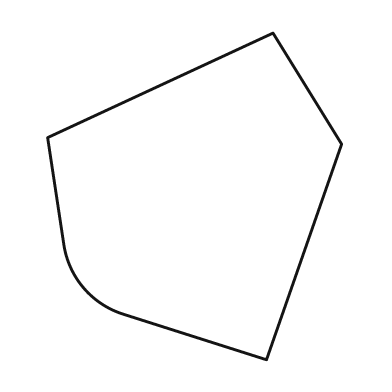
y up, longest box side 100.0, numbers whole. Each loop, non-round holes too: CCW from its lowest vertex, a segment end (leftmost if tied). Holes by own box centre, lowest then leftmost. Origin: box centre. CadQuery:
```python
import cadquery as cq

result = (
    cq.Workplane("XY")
    .moveTo(22.0, -50.0)
    .lineTo(45.0, 16.0)
    .lineTo(24.0, 50.0)
    .lineTo(-45.0, 18.0)
    .lineTo(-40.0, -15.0)
    .threePointArc((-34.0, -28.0), (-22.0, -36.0))
    .close()
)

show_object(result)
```